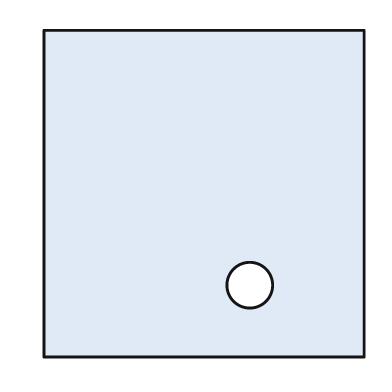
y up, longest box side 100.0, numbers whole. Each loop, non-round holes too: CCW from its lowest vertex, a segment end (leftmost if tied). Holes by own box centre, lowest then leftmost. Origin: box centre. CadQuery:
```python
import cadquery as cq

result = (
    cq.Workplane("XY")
    .moveTo(-49.0, -50.0)
    .lineTo(49.0, -50.0)
    .lineTo(49.0, 50.0)
    .lineTo(-49.0, 50.0)
    .close()
    .moveTo(14.0, -28.0)
    .circle(7.0)
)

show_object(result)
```